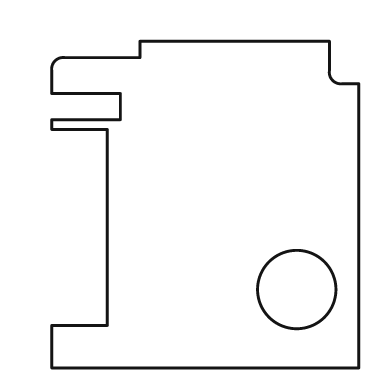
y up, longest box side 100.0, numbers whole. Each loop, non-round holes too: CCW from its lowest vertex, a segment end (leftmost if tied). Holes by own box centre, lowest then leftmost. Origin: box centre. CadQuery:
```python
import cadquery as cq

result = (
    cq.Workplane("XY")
    .moveTo(-47.0, -50.0)
    .lineTo(47.0, -50.0)
    .lineTo(47.0, 37.0)
    .lineTo(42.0, 37.0)
    .threePointArc((39.0, 38.0), (38.0, 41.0))
    .lineTo(38.0, 50.0)
    .lineTo(-20.0, 50.0)
    .lineTo(-20.0, 45.0)
    .lineTo(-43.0, 45.0)
    .threePointArc((-46.0, 44.0), (-47.0, 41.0))
    .lineTo(-47.0, 34.0)
    .lineTo(-26.0, 34.0)
    .lineTo(-26.0, 26.0)
    .lineTo(-47.0, 26.0)
    .lineTo(-47.0, 23.0)
    .lineTo(-30.0, 23.0)
    .lineTo(-30.0, -37.0)
    .lineTo(-47.0, -37.0)
    .close()
    .moveTo(28.0, -26.0)
    .circle(12.0)
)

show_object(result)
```